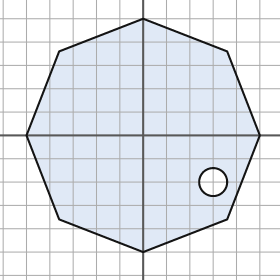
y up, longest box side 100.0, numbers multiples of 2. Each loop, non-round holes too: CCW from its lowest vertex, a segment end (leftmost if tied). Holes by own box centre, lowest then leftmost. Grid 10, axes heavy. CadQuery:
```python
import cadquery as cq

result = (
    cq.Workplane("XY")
    .moveTo(0.0, -50.0)
    .lineTo(36.0, -36.0)
    .lineTo(50.0, 0.0)
    .lineTo(36.0, 36.0)
    .lineTo(0.0, 50.0)
    .lineTo(-36.0, 36.0)
    .lineTo(-50.0, 0.0)
    .lineTo(-36.0, -36.0)
    .close()
    .moveTo(30.0, -20.0)
    .circle(6.0)
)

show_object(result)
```